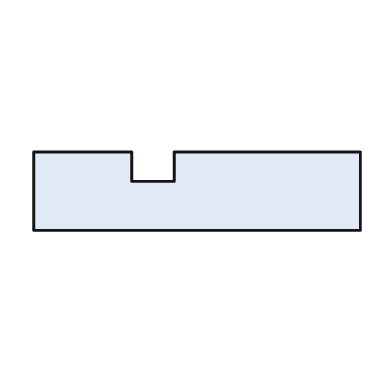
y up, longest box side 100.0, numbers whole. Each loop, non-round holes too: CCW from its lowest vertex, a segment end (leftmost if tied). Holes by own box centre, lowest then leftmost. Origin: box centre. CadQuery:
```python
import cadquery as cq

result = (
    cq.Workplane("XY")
    .moveTo(-50.0, -12.0)
    .lineTo(50.0, -12.0)
    .lineTo(50.0, 12.0)
    .lineTo(-7.0, 12.0)
    .lineTo(-7.0, 3.0)
    .lineTo(-20.0, 3.0)
    .lineTo(-20.0, 12.0)
    .lineTo(-50.0, 12.0)
    .close()
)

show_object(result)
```